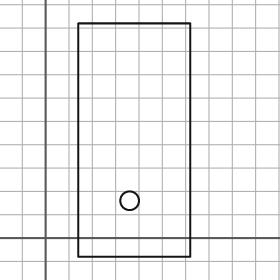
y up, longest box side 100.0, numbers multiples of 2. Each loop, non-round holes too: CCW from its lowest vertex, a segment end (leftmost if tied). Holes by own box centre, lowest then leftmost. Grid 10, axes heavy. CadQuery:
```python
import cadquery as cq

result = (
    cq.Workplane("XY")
    .moveTo(14.0, -8.0)
    .lineTo(62.0, -8.0)
    .lineTo(62.0, 92.0)
    .lineTo(14.0, 92.0)
    .close()
    .moveTo(36.0, 16.0)
    .circle(4.0)
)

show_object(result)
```